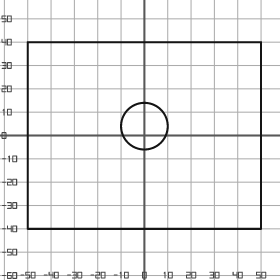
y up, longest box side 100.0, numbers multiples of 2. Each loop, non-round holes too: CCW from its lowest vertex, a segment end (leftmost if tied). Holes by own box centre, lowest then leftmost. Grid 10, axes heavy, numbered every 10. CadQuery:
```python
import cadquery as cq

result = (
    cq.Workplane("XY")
    .moveTo(-50.0, -40.0)
    .lineTo(50.0, -40.0)
    .lineTo(50.0, 40.0)
    .lineTo(-50.0, 40.0)
    .close()
    .moveTo(0.0, 4.0)
    .circle(10.0)
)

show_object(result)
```